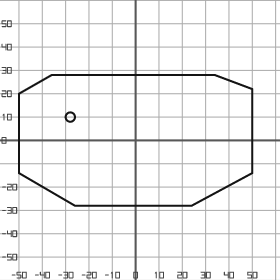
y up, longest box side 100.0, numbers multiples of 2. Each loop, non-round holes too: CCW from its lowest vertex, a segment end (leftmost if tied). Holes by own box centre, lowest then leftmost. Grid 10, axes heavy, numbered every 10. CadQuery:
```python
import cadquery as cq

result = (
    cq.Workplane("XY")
    .moveTo(-26.0, -28.0)
    .lineTo(24.0, -28.0)
    .lineTo(50.0, -14.0)
    .lineTo(50.0, 22.0)
    .lineTo(34.0, 28.0)
    .lineTo(-36.0, 28.0)
    .lineTo(-50.0, 20.0)
    .lineTo(-50.0, -14.0)
    .close()
    .moveTo(-28.0, 10.0)
    .circle(2.0)
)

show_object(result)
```